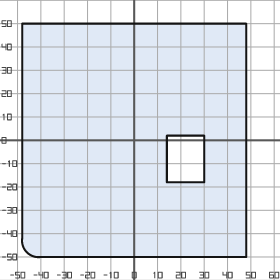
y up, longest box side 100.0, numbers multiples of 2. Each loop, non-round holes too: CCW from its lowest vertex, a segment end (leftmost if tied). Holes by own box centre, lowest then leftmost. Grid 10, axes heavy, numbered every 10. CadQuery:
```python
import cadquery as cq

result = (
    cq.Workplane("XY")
    .moveTo(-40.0, -50.0)
    .lineTo(48.0, -50.0)
    .lineTo(48.0, 50.0)
    .lineTo(-48.0, 50.0)
    .lineTo(-48.0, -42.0)
    .threePointArc((-46.0, -48.0), (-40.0, -50.0))
    .close()
    .moveTo(14.0, -18.0)
    .lineTo(30.0, -18.0)
    .lineTo(30.0, 2.0)
    .lineTo(14.0, 2.0)
    .close()
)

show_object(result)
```